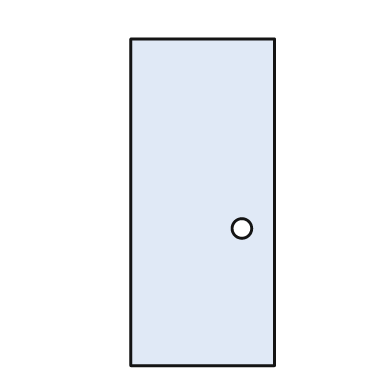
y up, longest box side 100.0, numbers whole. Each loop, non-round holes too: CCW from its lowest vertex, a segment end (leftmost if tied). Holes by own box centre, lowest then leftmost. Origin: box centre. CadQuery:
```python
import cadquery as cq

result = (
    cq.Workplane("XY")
    .moveTo(-22.0, -50.0)
    .lineTo(22.0, -50.0)
    .lineTo(22.0, 50.0)
    .lineTo(-22.0, 50.0)
    .close()
    .moveTo(12.0, -8.0)
    .circle(3.0)
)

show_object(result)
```